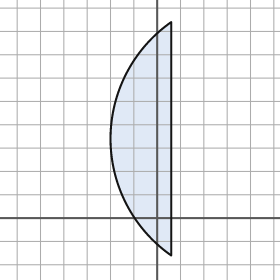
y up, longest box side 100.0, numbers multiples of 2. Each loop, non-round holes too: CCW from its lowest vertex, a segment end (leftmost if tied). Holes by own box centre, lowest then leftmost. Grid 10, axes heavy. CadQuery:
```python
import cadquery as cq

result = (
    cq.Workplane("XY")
    .moveTo(6.0, -16.0)
    .lineTo(6.0, 84.0)
    .threePointArc((-20.0, 34.0), (6.0, -16.0))
    .close()
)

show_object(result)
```